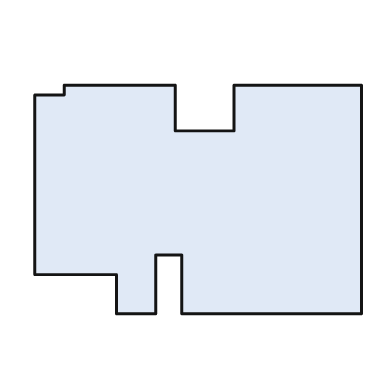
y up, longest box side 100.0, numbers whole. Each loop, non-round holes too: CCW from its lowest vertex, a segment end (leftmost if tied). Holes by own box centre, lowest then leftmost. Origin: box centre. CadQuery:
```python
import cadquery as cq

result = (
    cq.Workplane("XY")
    .moveTo(-25.0, -35.0)
    .lineTo(-13.0, -35.0)
    .lineTo(-13.0, -17.0)
    .lineTo(-5.0, -17.0)
    .lineTo(-5.0, -35.0)
    .lineTo(50.0, -35.0)
    .lineTo(50.0, 35.0)
    .lineTo(11.0, 35.0)
    .lineTo(11.0, 21.0)
    .lineTo(-7.0, 21.0)
    .lineTo(-7.0, 35.0)
    .lineTo(-41.0, 35.0)
    .lineTo(-41.0, 32.0)
    .lineTo(-50.0, 32.0)
    .lineTo(-50.0, -23.0)
    .lineTo(-25.0, -23.0)
    .close()
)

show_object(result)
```